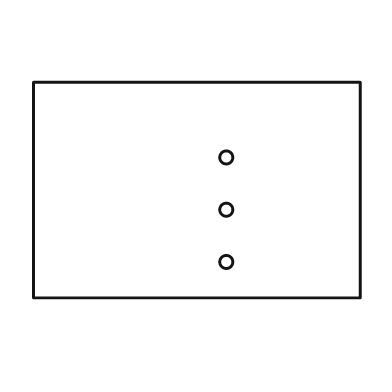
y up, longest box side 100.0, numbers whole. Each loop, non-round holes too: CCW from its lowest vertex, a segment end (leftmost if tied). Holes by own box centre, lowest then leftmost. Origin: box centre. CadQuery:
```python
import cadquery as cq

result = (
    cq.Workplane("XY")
    .moveTo(-50.0, -33.0)
    .lineTo(50.0, -33.0)
    .lineTo(50.0, 33.0)
    .lineTo(-50.0, 33.0)
    .close()
    .moveTo(9.0, -22.0)
    .circle(2.0)
    .moveTo(9.0, -6.0)
    .circle(2.0)
    .moveTo(9.0, 10.0)
    .circle(2.0)
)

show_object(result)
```